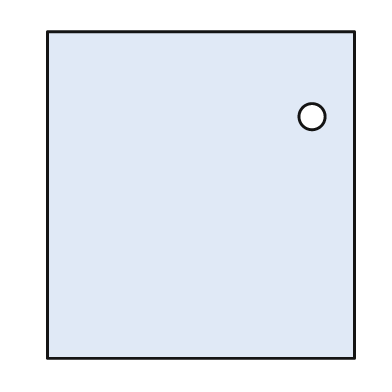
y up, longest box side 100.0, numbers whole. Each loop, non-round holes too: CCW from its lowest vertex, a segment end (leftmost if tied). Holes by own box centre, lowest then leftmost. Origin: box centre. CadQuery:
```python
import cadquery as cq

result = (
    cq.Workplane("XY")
    .moveTo(-47.0, -50.0)
    .lineTo(47.0, -50.0)
    .lineTo(47.0, 50.0)
    .lineTo(-47.0, 50.0)
    .close()
    .moveTo(34.0, 24.0)
    .circle(4.0)
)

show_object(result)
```